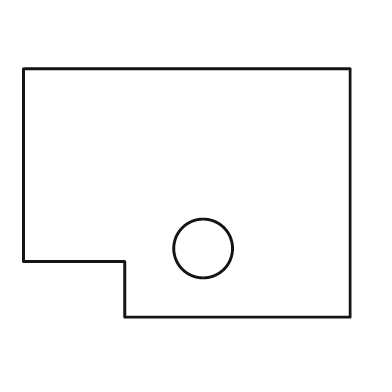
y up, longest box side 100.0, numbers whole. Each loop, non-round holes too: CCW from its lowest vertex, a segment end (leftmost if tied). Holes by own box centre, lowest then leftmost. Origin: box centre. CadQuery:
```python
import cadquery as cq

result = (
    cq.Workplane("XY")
    .moveTo(-19.0, -38.0)
    .lineTo(50.0, -38.0)
    .lineTo(50.0, 38.0)
    .lineTo(-50.0, 38.0)
    .lineTo(-50.0, -21.0)
    .lineTo(-19.0, -21.0)
    .close()
    .moveTo(5.0, -17.0)
    .circle(9.0)
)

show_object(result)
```